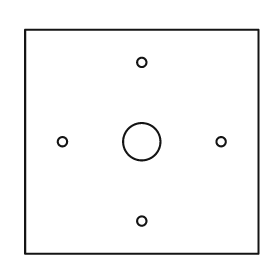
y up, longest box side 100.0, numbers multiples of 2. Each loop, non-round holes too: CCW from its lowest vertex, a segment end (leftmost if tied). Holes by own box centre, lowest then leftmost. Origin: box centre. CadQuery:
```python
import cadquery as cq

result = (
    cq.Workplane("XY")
    .moveTo(-50.0, -48.0)
    .lineTo(50.0, -48.0)
    .lineTo(50.0, 48.0)
    .lineTo(-50.0, 48.0)
    .close()
    .moveTo(0.0, -34.0)
    .circle(2.0)
    .moveTo(-34.0, 0.0)
    .circle(2.0)
    .moveTo(0.0, 0.0)
    .circle(8.0)
    .moveTo(34.0, 0.0)
    .circle(2.0)
    .moveTo(0.0, 34.0)
    .circle(2.0)
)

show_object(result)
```